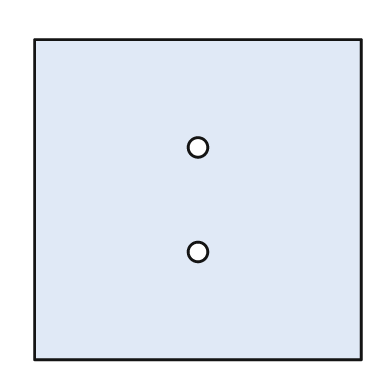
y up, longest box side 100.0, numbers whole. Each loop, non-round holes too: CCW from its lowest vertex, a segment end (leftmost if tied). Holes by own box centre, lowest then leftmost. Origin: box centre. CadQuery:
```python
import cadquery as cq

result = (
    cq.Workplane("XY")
    .moveTo(-50.0, -49.0)
    .lineTo(50.0, -49.0)
    .lineTo(50.0, 49.0)
    .lineTo(-50.0, 49.0)
    .close()
    .moveTo(0.0, -16.0)
    .circle(3.0)
    .moveTo(0.0, 16.0)
    .circle(3.0)
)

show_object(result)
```